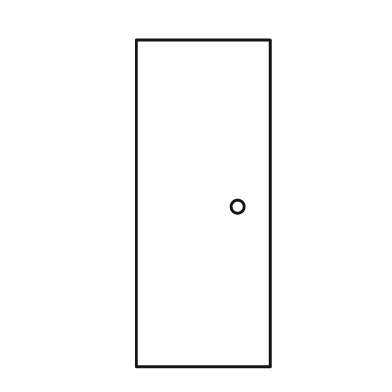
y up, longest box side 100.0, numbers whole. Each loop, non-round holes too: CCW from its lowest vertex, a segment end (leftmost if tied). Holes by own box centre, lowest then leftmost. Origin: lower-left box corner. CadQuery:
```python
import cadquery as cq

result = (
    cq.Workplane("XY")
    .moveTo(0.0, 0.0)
    .lineTo(41.0, 0.0)
    .lineTo(41.0, 100.0)
    .lineTo(0.0, 100.0)
    .close()
    .moveTo(31.0, 49.0)
    .circle(2.0)
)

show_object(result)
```